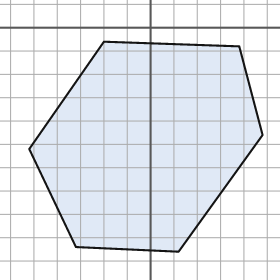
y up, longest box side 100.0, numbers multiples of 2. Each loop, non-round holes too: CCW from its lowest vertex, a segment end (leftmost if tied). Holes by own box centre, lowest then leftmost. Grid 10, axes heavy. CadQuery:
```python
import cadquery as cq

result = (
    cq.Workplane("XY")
    .moveTo(12.0, -96.0)
    .lineTo(48.0, -46.0)
    .lineTo(38.0, -8.0)
    .lineTo(-20.0, -6.0)
    .lineTo(-52.0, -52.0)
    .lineTo(-32.0, -94.0)
    .close()
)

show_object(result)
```